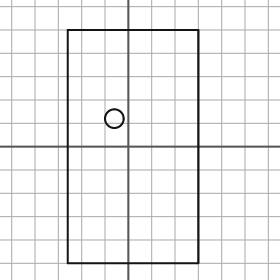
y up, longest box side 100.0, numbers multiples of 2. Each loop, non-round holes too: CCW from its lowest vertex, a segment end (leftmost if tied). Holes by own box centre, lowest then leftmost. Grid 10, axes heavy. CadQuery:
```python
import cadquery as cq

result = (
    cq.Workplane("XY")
    .moveTo(-26.0, -50.0)
    .lineTo(30.0, -50.0)
    .lineTo(30.0, 50.0)
    .lineTo(-26.0, 50.0)
    .close()
    .moveTo(-6.0, 12.0)
    .circle(4.0)
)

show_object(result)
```